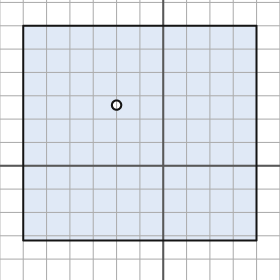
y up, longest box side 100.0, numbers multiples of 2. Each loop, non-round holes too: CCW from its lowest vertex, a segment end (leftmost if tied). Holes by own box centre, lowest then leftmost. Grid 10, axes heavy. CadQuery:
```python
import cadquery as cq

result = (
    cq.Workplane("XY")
    .moveTo(-60.0, -32.0)
    .lineTo(40.0, -32.0)
    .lineTo(40.0, 60.0)
    .lineTo(-60.0, 60.0)
    .close()
    .moveTo(-20.0, 26.0)
    .circle(2.0)
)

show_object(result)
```